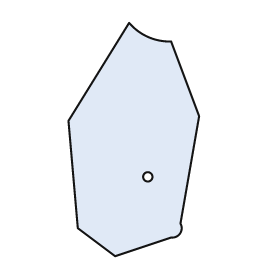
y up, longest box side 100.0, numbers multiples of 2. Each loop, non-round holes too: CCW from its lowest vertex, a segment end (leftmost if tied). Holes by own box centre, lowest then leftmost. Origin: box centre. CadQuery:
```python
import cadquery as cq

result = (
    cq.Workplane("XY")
    .moveTo(-8.0, -50.0)
    .lineTo(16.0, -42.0)
    .threePointArc((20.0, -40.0), (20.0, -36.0))
    .lineTo(28.0, 10.0)
    .lineTo(16.0, 42.0)
    .threePointArc((6.0, 44.0), (-2.0, 50.0))
    .lineTo(-28.0, 8.0)
    .lineTo(-24.0, -38.0)
    .close()
    .moveTo(6.0, -16.0)
    .circle(2.0)
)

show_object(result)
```